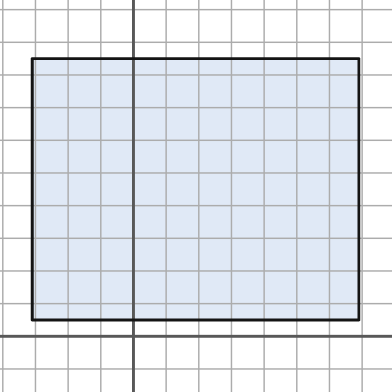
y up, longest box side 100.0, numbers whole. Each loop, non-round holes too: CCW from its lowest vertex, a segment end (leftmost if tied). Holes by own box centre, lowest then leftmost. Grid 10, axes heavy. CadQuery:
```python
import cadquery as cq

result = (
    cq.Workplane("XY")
    .moveTo(-31.0, 5.0)
    .lineTo(69.0, 5.0)
    .lineTo(69.0, 85.0)
    .lineTo(-31.0, 85.0)
    .close()
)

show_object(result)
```